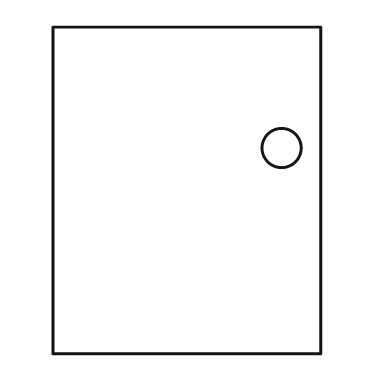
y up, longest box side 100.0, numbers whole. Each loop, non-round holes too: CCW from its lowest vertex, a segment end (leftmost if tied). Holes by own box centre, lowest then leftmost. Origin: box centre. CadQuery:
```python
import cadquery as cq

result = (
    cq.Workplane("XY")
    .moveTo(-41.0, -50.0)
    .lineTo(41.0, -50.0)
    .lineTo(41.0, 50.0)
    .lineTo(-41.0, 50.0)
    .close()
    .moveTo(29.0, 13.0)
    .circle(6.0)
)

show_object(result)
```